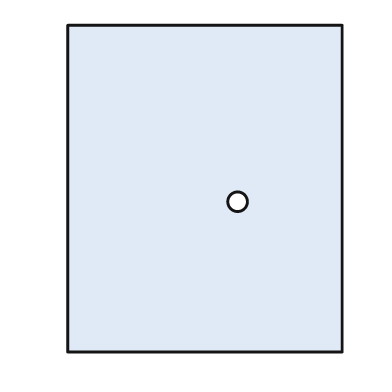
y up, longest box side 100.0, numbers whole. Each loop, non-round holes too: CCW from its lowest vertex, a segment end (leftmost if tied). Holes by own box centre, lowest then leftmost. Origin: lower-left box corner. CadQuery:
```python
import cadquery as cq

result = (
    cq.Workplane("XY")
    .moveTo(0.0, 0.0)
    .lineTo(84.0, 0.0)
    .lineTo(84.0, 100.0)
    .lineTo(0.0, 100.0)
    .close()
    .moveTo(52.0, 46.0)
    .circle(3.0)
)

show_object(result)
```